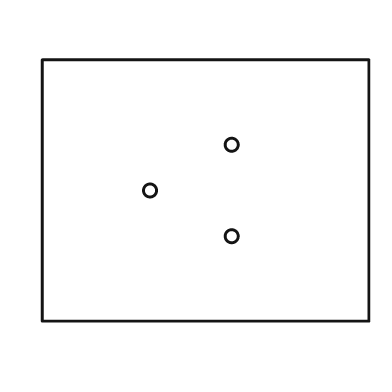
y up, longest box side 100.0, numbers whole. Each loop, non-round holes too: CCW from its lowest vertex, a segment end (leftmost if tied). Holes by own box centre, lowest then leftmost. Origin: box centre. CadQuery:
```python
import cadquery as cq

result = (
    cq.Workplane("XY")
    .moveTo(-50.0, -40.0)
    .lineTo(50.0, -40.0)
    .lineTo(50.0, 40.0)
    .lineTo(-50.0, 40.0)
    .close()
    .moveTo(8.0, -14.0)
    .circle(2.0)
    .moveTo(-17.0, 0.0)
    .circle(2.0)
    .moveTo(8.0, 14.0)
    .circle(2.0)
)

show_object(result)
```